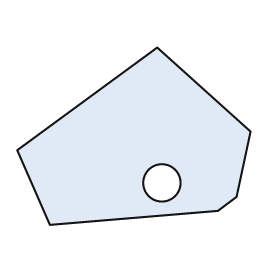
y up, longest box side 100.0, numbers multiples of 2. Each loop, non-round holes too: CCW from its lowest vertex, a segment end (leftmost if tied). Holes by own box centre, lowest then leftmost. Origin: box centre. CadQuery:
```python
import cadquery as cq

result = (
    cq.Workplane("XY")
    .moveTo(-36.0, -38.0)
    .lineTo(36.0, -32.0)
    .lineTo(44.0, -26.0)
    .lineTo(50.0, 2.0)
    .lineTo(10.0, 38.0)
    .lineTo(-50.0, -6.0)
    .close()
    .moveTo(12.0, -20.0)
    .circle(8.0)
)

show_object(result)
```